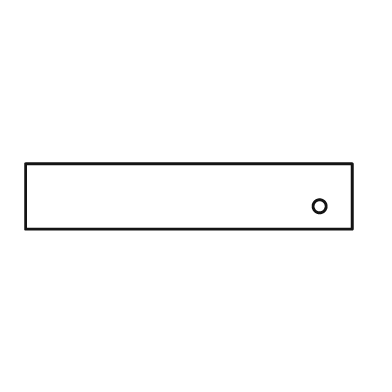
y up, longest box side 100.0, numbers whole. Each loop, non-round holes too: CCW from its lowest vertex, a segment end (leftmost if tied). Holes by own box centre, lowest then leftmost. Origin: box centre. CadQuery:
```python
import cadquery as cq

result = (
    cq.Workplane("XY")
    .moveTo(-50.0, -10.0)
    .lineTo(50.0, -10.0)
    .lineTo(50.0, 10.0)
    .lineTo(-50.0, 10.0)
    .close()
    .moveTo(40.0, -3.0)
    .circle(2.0)
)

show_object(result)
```